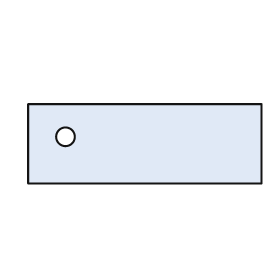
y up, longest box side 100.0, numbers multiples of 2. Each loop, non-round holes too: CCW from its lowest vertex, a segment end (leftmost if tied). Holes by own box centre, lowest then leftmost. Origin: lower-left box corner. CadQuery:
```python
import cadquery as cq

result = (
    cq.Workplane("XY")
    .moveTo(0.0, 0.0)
    .lineTo(100.0, 0.0)
    .lineTo(100.0, 34.0)
    .lineTo(0.0, 34.0)
    .close()
    .moveTo(16.0, 20.0)
    .circle(4.0)
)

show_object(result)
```